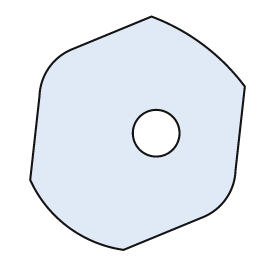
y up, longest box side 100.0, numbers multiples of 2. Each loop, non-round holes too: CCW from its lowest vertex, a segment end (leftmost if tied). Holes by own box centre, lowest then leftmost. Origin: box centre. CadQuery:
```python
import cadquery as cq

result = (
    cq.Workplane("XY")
    .moveTo(-6.0, -50.0)
    .lineTo(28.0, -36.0)
    .threePointArc((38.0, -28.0), (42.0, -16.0))
    .lineTo(46.0, 20.0)
    .threePointArc((28.0, 38.0), (6.0, 50.0))
    .lineTo(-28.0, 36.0)
    .threePointArc((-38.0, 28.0), (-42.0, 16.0))
    .lineTo(-46.0, -20.0)
    .threePointArc((-30.0, -40.0), (-6.0, -50.0))
    .close()
    .moveTo(8.0, 0.0)
    .circle(10.0)
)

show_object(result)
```